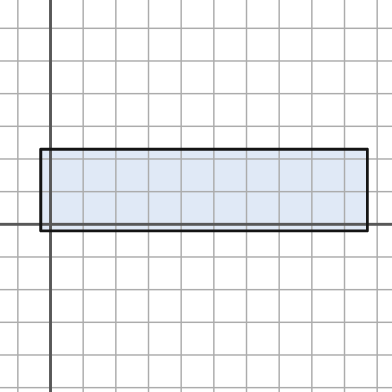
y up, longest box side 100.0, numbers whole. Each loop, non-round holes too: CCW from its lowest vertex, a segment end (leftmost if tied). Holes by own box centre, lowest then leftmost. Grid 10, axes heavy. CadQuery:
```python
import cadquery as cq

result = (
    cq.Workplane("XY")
    .moveTo(-3.0, -2.0)
    .lineTo(97.0, -2.0)
    .lineTo(97.0, 23.0)
    .lineTo(-3.0, 23.0)
    .close()
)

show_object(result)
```